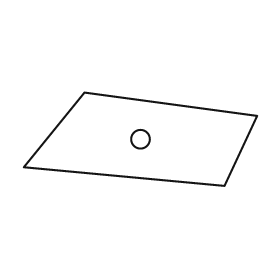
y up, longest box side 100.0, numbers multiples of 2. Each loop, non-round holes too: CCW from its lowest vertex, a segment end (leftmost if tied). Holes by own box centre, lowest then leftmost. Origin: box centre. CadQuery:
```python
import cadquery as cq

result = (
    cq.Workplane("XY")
    .moveTo(36.0, -20.0)
    .lineTo(50.0, 10.0)
    .lineTo(-24.0, 20.0)
    .lineTo(-50.0, -12.0)
    .close()
    .moveTo(0.0, 0.0)
    .circle(4.0)
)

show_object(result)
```